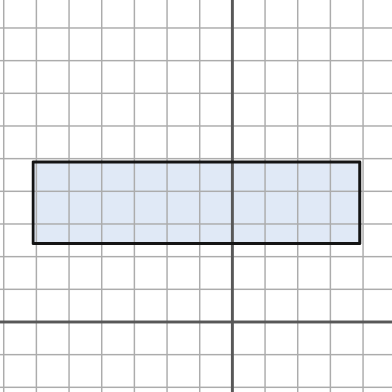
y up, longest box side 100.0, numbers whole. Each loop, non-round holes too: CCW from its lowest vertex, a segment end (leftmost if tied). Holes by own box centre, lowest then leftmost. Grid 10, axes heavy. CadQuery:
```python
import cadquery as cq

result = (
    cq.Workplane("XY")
    .moveTo(-61.0, 24.0)
    .lineTo(39.0, 24.0)
    .lineTo(39.0, 49.0)
    .lineTo(-61.0, 49.0)
    .close()
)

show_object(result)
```